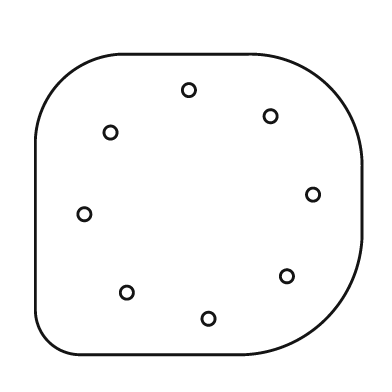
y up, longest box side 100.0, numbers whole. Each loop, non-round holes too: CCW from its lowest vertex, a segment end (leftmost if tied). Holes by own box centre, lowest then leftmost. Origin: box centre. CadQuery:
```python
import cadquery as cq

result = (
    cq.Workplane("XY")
    .moveTo(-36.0, -46.0)
    .lineTo(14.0, -46.0)
    .threePointArc((39.0, -35.0), (50.0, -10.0))
    .lineTo(50.0, 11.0)
    .threePointArc((40.0, 36.0), (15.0, 46.0))
    .lineTo(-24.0, 46.0)
    .threePointArc((-42.0, 38.0), (-50.0, 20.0))
    .lineTo(-50.0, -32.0)
    .threePointArc((-46.0, -42.0), (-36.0, -46.0))
    .close()
    .moveTo(3.0, -35.0)
    .circle(2.0)
    .moveTo(-22.0, -27.0)
    .circle(2.0)
    .moveTo(27.0, -22.0)
    .circle(2.0)
    .moveTo(-35.0, -3.0)
    .circle(2.0)
    .moveTo(35.0, 3.0)
    .circle(2.0)
    .moveTo(-27.0, 22.0)
    .circle(2.0)
    .moveTo(22.0, 27.0)
    .circle(2.0)
    .moveTo(-3.0, 35.0)
    .circle(2.0)
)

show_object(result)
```